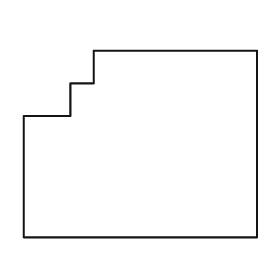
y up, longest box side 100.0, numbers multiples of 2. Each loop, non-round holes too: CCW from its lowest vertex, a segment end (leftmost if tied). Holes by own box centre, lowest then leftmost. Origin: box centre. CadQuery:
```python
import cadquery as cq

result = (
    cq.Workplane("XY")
    .moveTo(-50.0, -40.0)
    .lineTo(50.0, -40.0)
    .lineTo(50.0, 40.0)
    .lineTo(-20.0, 40.0)
    .lineTo(-20.0, 26.0)
    .lineTo(-30.0, 26.0)
    .lineTo(-30.0, 12.0)
    .lineTo(-50.0, 12.0)
    .close()
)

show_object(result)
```